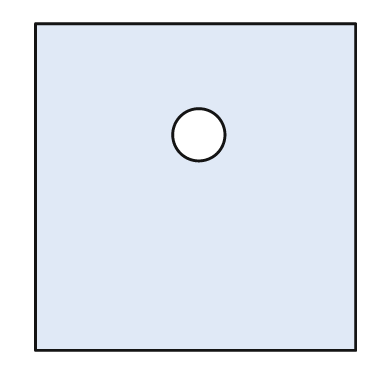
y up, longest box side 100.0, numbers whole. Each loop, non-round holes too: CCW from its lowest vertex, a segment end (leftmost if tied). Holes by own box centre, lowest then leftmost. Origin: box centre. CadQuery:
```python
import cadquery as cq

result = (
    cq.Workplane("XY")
    .moveTo(-49.0, -50.0)
    .lineTo(49.0, -50.0)
    .lineTo(49.0, 50.0)
    .lineTo(-49.0, 50.0)
    .close()
    .moveTo(1.0, 16.0)
    .circle(8.0)
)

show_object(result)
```